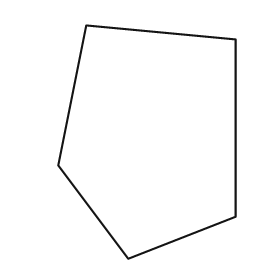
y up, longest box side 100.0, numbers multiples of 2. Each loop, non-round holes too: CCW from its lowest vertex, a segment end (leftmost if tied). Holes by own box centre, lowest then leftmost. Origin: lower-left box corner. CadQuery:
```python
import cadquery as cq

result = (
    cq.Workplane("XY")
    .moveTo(30.0, 0.0)
    .lineTo(76.0, 18.0)
    .lineTo(76.0, 94.0)
    .lineTo(12.0, 100.0)
    .lineTo(0.0, 40.0)
    .close()
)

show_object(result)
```